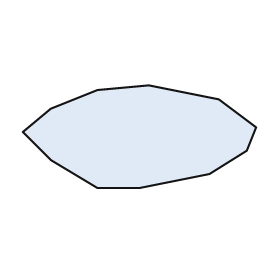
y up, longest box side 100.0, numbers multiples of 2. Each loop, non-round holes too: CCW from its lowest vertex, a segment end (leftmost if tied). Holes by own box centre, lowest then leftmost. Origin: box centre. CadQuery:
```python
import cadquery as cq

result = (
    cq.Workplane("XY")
    .moveTo(-18.0, -22.0)
    .lineTo(0.0, -22.0)
    .lineTo(30.0, -16.0)
    .lineTo(46.0, -6.0)
    .lineTo(50.0, 4.0)
    .lineTo(34.0, 16.0)
    .lineTo(4.0, 22.0)
    .lineTo(-18.0, 20.0)
    .lineTo(-38.0, 12.0)
    .lineTo(-50.0, 2.0)
    .lineTo(-38.0, -10.0)
    .close()
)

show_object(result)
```